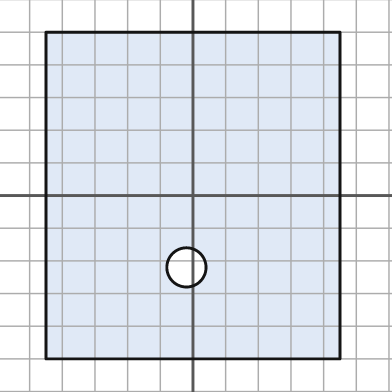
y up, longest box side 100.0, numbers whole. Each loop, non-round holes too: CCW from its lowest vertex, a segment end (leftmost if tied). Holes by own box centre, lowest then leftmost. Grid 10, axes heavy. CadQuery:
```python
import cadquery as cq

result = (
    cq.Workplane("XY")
    .moveTo(-45.0, -50.0)
    .lineTo(45.0, -50.0)
    .lineTo(45.0, 50.0)
    .lineTo(-45.0, 50.0)
    .close()
    .moveTo(-2.0, -22.0)
    .circle(6.0)
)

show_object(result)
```